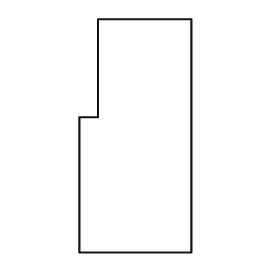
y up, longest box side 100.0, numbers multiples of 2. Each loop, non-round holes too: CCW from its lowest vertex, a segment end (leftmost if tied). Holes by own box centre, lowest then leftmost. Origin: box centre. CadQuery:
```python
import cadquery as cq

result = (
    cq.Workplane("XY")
    .moveTo(-24.0, -50.0)
    .lineTo(24.0, -50.0)
    .lineTo(24.0, 50.0)
    .lineTo(-16.0, 50.0)
    .lineTo(-16.0, 8.0)
    .lineTo(-24.0, 8.0)
    .close()
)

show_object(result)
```